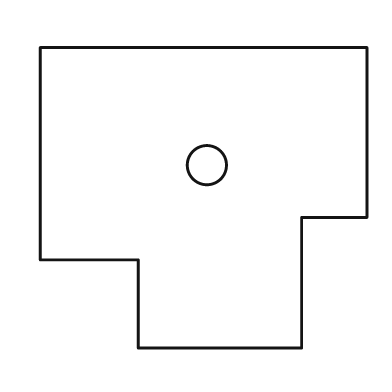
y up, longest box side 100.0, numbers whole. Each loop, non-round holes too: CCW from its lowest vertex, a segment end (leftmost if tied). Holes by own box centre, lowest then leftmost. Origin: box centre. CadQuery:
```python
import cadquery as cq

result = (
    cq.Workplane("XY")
    .moveTo(-20.0, -46.0)
    .lineTo(30.0, -46.0)
    .lineTo(30.0, -6.0)
    .lineTo(50.0, -6.0)
    .lineTo(50.0, 46.0)
    .lineTo(-50.0, 46.0)
    .lineTo(-50.0, -19.0)
    .lineTo(-20.0, -19.0)
    .close()
    .moveTo(1.0, 10.0)
    .circle(6.0)
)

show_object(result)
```